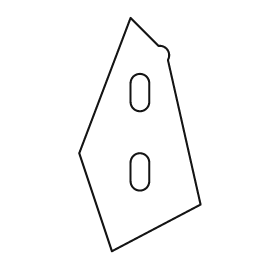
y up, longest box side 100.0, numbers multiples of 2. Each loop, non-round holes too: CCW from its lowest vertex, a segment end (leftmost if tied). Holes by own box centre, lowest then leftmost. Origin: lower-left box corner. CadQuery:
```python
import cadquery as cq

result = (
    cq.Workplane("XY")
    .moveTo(14.0, 0.0)
    .lineTo(52.0, 20.0)
    .lineTo(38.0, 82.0)
    .threePointArc((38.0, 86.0), (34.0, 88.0))
    .lineTo(22.0, 100.0)
    .lineTo(0.0, 42.0)
    .close()
    .moveTo(22.0, 30.0)
    .threePointArc((26.0, 26.0), (30.0, 30.0))
    .lineTo(30.0, 38.0)
    .threePointArc((26.0, 42.0), (22.0, 38.0))
    .close()
    .moveTo(22.0, 64.0)
    .threePointArc((26.0, 60.0), (30.0, 64.0))
    .lineTo(30.0, 72.0)
    .threePointArc((26.0, 76.0), (22.0, 72.0))
    .close()
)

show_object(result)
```